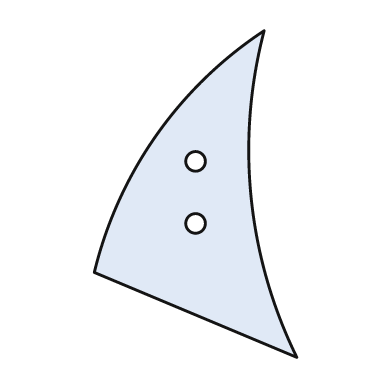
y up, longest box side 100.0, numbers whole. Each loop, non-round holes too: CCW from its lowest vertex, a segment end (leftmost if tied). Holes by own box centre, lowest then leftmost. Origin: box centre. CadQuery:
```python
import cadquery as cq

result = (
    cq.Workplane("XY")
    .moveTo(31.0, -50.0)
    .threePointArc((17.0, -1.0), (21.0, 50.0))
    .threePointArc((-12.0, 18.0), (-31.0, -24.0))
    .close()
    .moveTo(0.0, -9.0)
    .circle(3.0)
    .moveTo(0.0, 10.0)
    .circle(3.0)
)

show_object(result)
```